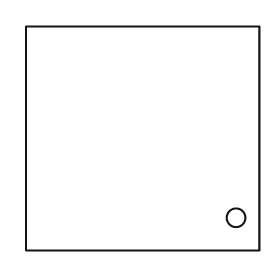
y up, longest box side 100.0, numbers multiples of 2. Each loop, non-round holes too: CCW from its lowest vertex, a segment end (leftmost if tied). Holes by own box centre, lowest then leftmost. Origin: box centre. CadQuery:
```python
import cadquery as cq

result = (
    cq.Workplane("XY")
    .moveTo(-50.0, -48.0)
    .lineTo(50.0, -48.0)
    .lineTo(50.0, 48.0)
    .lineTo(-50.0, 48.0)
    .close()
    .moveTo(40.0, -34.0)
    .circle(4.0)
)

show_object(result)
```